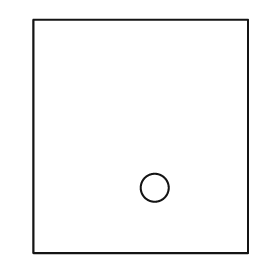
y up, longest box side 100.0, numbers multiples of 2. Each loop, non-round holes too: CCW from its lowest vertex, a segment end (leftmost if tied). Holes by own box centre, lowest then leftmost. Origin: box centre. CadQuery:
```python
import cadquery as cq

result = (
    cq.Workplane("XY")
    .moveTo(-46.0, -50.0)
    .lineTo(46.0, -50.0)
    .lineTo(46.0, 50.0)
    .lineTo(-46.0, 50.0)
    .close()
    .moveTo(6.0, -22.0)
    .circle(6.0)
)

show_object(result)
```